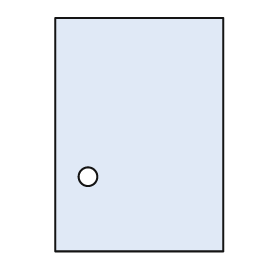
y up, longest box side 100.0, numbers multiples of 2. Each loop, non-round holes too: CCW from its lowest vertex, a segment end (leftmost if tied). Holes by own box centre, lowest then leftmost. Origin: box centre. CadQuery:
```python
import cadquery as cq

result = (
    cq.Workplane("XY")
    .moveTo(-36.0, -50.0)
    .lineTo(36.0, -50.0)
    .lineTo(36.0, 50.0)
    .lineTo(-36.0, 50.0)
    .close()
    .moveTo(-22.0, -18.0)
    .circle(4.0)
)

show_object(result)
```